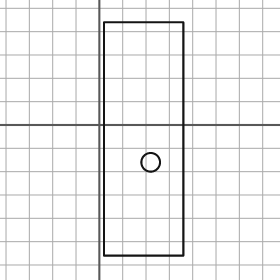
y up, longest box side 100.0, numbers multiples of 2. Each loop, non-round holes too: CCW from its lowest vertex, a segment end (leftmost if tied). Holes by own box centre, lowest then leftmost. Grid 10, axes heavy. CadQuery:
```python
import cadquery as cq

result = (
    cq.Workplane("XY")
    .moveTo(2.0, -56.0)
    .lineTo(36.0, -56.0)
    .lineTo(36.0, 44.0)
    .lineTo(2.0, 44.0)
    .close()
    .moveTo(22.0, -16.0)
    .circle(4.0)
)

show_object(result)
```